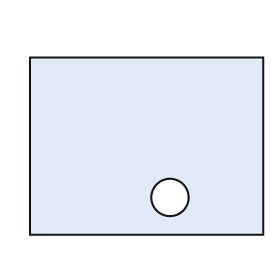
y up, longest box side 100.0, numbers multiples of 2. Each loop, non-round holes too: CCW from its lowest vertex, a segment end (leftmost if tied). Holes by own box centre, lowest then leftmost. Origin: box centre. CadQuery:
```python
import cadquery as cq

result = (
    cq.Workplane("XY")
    .moveTo(-50.0, -38.0)
    .lineTo(50.0, -38.0)
    .lineTo(50.0, 38.0)
    .lineTo(-50.0, 38.0)
    .close()
    .moveTo(10.0, -22.0)
    .circle(8.0)
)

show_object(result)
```